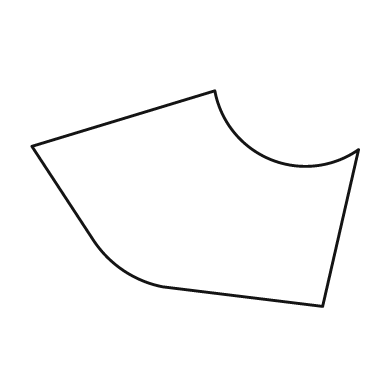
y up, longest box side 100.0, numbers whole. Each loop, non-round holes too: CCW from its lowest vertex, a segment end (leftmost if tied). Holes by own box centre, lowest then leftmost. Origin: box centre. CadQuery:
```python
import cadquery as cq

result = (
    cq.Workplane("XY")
    .moveTo(39.0, -33.0)
    .lineTo(50.0, 15.0)
    .threePointArc((23.0, 12.0), (6.0, 33.0))
    .lineTo(-50.0, 16.0)
    .lineTo(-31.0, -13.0)
    .threePointArc((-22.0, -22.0), (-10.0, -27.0))
    .close()
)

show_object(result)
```